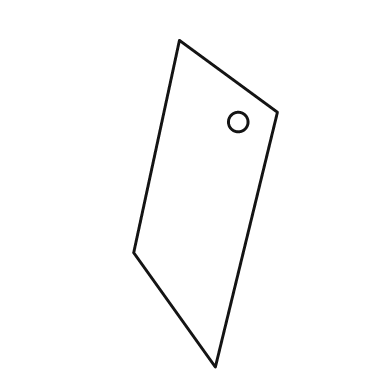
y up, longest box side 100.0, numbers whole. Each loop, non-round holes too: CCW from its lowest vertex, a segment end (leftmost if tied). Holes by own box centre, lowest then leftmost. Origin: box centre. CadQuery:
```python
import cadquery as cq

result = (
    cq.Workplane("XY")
    .moveTo(3.0, -50.0)
    .lineTo(22.0, 28.0)
    .lineTo(-8.0, 50.0)
    .lineTo(-22.0, -15.0)
    .close()
    .moveTo(10.0, 25.0)
    .circle(3.0)
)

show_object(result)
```